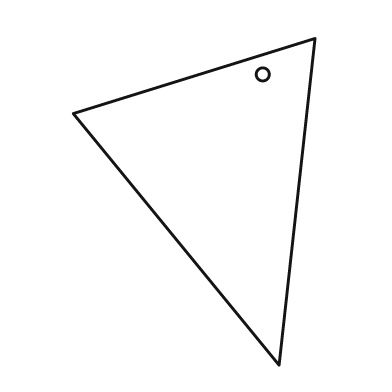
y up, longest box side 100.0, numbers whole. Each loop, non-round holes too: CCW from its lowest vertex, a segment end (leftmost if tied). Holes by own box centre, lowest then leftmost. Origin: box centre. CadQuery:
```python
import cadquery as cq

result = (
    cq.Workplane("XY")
    .moveTo(26.0, -50.0)
    .lineTo(37.0, 50.0)
    .lineTo(-37.0, 27.0)
    .close()
    .moveTo(21.0, 39.0)
    .circle(2.0)
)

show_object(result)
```